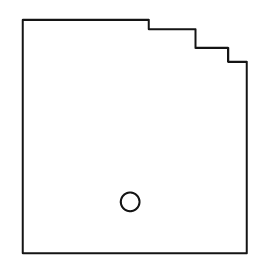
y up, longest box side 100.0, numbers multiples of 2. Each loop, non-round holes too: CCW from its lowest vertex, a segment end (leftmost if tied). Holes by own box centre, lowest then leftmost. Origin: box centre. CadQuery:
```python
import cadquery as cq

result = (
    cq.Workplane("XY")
    .moveTo(-48.0, -50.0)
    .lineTo(48.0, -50.0)
    .lineTo(48.0, 32.0)
    .lineTo(40.0, 32.0)
    .lineTo(40.0, 38.0)
    .lineTo(26.0, 38.0)
    .lineTo(26.0, 46.0)
    .lineTo(6.0, 46.0)
    .lineTo(6.0, 50.0)
    .lineTo(-48.0, 50.0)
    .close()
    .moveTo(-2.0, -28.0)
    .circle(4.0)
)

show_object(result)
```